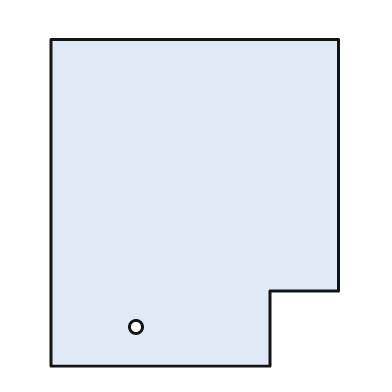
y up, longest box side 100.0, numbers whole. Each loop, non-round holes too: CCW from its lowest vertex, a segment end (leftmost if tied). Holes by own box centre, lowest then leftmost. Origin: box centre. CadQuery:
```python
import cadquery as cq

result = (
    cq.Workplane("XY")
    .moveTo(-44.0, -50.0)
    .lineTo(23.0, -50.0)
    .lineTo(23.0, -27.0)
    .lineTo(44.0, -27.0)
    .lineTo(44.0, 50.0)
    .lineTo(-44.0, 50.0)
    .close()
    .moveTo(-18.0, -38.0)
    .circle(2.0)
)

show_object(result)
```